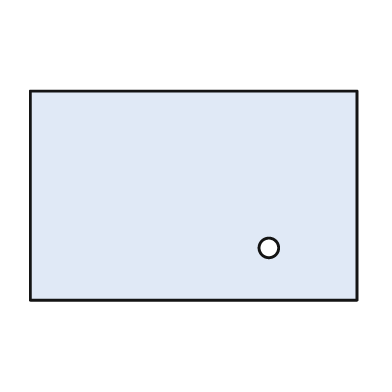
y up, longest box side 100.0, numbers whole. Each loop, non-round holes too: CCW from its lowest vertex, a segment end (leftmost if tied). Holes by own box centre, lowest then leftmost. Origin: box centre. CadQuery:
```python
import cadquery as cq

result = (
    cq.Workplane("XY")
    .moveTo(-50.0, -32.0)
    .lineTo(50.0, -32.0)
    .lineTo(50.0, 32.0)
    .lineTo(-50.0, 32.0)
    .close()
    .moveTo(23.0, -16.0)
    .circle(3.0)
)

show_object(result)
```